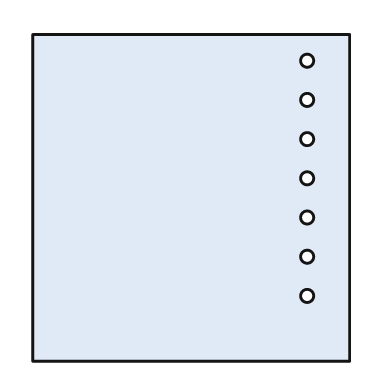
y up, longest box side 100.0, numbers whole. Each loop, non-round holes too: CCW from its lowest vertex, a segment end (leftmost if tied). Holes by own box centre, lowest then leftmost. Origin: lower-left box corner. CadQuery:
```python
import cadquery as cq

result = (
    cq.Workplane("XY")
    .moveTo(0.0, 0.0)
    .lineTo(97.0, 0.0)
    .lineTo(97.0, 100.0)
    .lineTo(0.0, 100.0)
    .close()
    .moveTo(84.0, 20.0)
    .circle(2.0)
    .moveTo(84.0, 32.0)
    .circle(2.0)
    .moveTo(84.0, 44.0)
    .circle(2.0)
    .moveTo(84.0, 56.0)
    .circle(2.0)
    .moveTo(84.0, 68.0)
    .circle(2.0)
    .moveTo(84.0, 80.0)
    .circle(2.0)
    .moveTo(84.0, 92.0)
    .circle(2.0)
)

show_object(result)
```